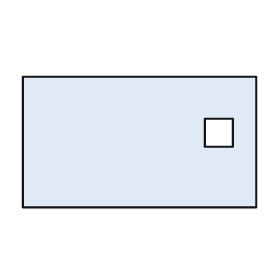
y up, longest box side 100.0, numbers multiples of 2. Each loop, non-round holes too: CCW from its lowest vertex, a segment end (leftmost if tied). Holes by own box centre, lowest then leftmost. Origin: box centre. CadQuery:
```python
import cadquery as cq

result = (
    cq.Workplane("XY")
    .moveTo(-50.0, -28.0)
    .lineTo(50.0, -28.0)
    .lineTo(50.0, 28.0)
    .lineTo(-50.0, 28.0)
    .close()
    .moveTo(28.0, -2.0)
    .lineTo(40.0, -2.0)
    .lineTo(40.0, 10.0)
    .lineTo(28.0, 10.0)
    .close()
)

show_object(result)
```